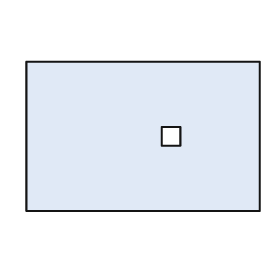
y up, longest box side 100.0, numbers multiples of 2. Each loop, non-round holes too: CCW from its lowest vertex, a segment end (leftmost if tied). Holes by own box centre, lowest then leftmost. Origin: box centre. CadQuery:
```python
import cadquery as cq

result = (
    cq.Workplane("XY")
    .moveTo(-50.0, -32.0)
    .lineTo(50.0, -32.0)
    .lineTo(50.0, 32.0)
    .lineTo(-50.0, 32.0)
    .close()
    .moveTo(8.0, -4.0)
    .lineTo(16.0, -4.0)
    .lineTo(16.0, 4.0)
    .lineTo(8.0, 4.0)
    .close()
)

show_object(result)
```